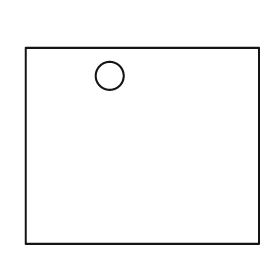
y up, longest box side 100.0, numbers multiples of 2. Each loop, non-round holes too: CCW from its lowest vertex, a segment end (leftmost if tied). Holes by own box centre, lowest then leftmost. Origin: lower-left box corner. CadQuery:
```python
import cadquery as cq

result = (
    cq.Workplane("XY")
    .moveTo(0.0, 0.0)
    .lineTo(100.0, 0.0)
    .lineTo(100.0, 84.0)
    .lineTo(0.0, 84.0)
    .close()
    .moveTo(36.0, 72.0)
    .circle(6.0)
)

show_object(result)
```